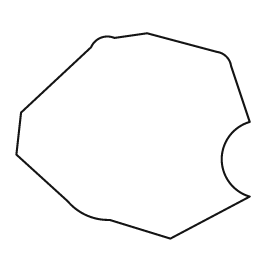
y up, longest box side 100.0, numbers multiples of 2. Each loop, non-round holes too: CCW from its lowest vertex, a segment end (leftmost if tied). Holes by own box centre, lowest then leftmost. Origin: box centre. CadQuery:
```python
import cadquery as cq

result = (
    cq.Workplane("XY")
    .moveTo(16.0, -44.0)
    .lineTo(50.0, -26.0)
    .threePointArc((38.0, -10.0), (50.0, 6.0))
    .lineTo(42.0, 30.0)
    .threePointArc((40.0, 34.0), (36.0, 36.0))
    .lineTo(6.0, 44.0)
    .lineTo(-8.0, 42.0)
    .threePointArc((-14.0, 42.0), (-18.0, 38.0))
    .lineTo(-48.0, 10.0)
    .lineTo(-50.0, -8.0)
    .lineTo(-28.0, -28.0)
    .threePointArc((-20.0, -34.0), (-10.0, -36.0))
    .close()
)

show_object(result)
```